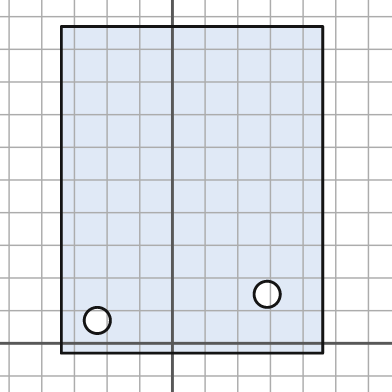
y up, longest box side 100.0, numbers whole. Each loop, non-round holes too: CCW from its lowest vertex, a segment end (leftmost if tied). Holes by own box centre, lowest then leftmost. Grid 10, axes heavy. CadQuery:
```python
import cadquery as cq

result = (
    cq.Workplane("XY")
    .moveTo(-34.0, -3.0)
    .lineTo(46.0, -3.0)
    .lineTo(46.0, 97.0)
    .lineTo(-34.0, 97.0)
    .close()
    .moveTo(-23.0, 7.0)
    .circle(4.0)
    .moveTo(29.0, 15.0)
    .circle(4.0)
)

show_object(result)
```